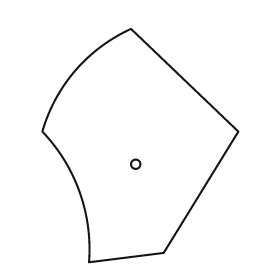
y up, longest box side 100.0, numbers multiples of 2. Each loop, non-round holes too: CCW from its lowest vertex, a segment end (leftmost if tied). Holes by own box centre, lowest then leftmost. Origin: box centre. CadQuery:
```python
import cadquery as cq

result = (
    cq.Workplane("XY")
    .moveTo(-22.0, -50.0)
    .lineTo(10.0, -46.0)
    .lineTo(42.0, 6.0)
    .lineTo(-4.0, 50.0)
    .threePointArc((-28.0, 32.0), (-42.0, 6.0))
    .threePointArc((-26.0, -20.0), (-22.0, -50.0))
    .close()
    .moveTo(-2.0, -8.0)
    .circle(2.0)
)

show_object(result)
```